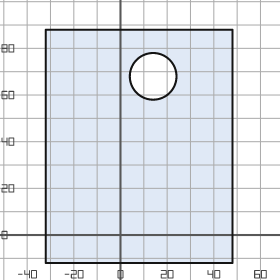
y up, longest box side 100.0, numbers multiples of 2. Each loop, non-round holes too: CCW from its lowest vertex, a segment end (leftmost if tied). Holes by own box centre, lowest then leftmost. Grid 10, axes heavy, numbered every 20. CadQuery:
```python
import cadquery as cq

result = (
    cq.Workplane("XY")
    .moveTo(-32.0, -12.0)
    .lineTo(48.0, -12.0)
    .lineTo(48.0, 88.0)
    .lineTo(-32.0, 88.0)
    .close()
    .moveTo(14.0, 68.0)
    .circle(10.0)
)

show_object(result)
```